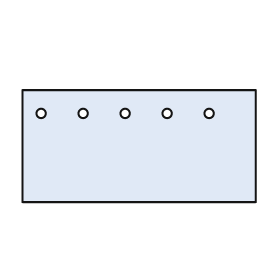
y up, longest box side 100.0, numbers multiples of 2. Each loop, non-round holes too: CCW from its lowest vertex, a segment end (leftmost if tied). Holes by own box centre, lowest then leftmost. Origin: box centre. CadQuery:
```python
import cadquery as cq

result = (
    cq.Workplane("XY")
    .moveTo(-50.0, -24.0)
    .lineTo(50.0, -24.0)
    .lineTo(50.0, 24.0)
    .lineTo(-50.0, 24.0)
    .close()
    .moveTo(-42.0, 14.0)
    .circle(2.0)
    .moveTo(-24.0, 14.0)
    .circle(2.0)
    .moveTo(-6.0, 14.0)
    .circle(2.0)
    .moveTo(12.0, 14.0)
    .circle(2.0)
    .moveTo(30.0, 14.0)
    .circle(2.0)
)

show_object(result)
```